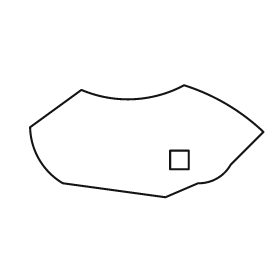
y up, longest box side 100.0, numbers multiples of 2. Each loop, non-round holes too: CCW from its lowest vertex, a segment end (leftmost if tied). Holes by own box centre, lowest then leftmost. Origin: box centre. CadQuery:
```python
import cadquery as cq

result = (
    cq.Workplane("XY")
    .moveTo(8.0, -24.0)
    .lineTo(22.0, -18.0)
    .threePointArc((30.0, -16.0), (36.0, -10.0))
    .lineTo(50.0, 4.0)
    .threePointArc((34.0, 16.0), (16.0, 24.0))
    .threePointArc((-6.0, 18.0), (-28.0, 22.0))
    .lineTo(-50.0, 6.0)
    .threePointArc((-46.0, -8.0), (-36.0, -18.0))
    .close()
    .moveTo(10.0, -12.0)
    .lineTo(18.0, -12.0)
    .lineTo(18.0, -4.0)
    .lineTo(10.0, -4.0)
    .close()
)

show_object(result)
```